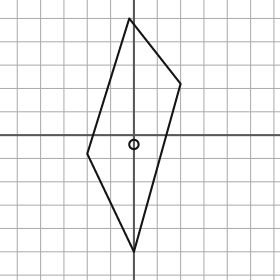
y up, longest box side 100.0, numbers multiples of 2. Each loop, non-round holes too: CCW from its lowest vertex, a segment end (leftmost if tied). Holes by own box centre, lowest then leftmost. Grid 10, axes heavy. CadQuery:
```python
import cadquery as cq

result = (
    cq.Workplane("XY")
    .moveTo(0.0, -50.0)
    .lineTo(20.0, 22.0)
    .lineTo(-2.0, 50.0)
    .lineTo(-20.0, -8.0)
    .close()
    .moveTo(0.0, -4.0)
    .circle(2.0)
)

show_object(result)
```